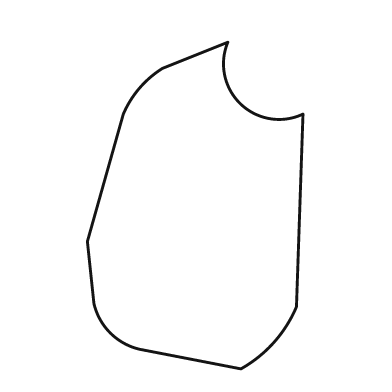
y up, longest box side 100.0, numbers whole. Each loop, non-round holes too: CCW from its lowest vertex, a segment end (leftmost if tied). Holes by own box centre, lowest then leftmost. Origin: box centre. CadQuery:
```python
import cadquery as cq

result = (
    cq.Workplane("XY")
    .moveTo(14.0, -50.0)
    .threePointArc((24.0, -42.0), (31.0, -31.0))
    .lineTo(33.0, 28.0)
    .threePointArc((14.0, 31.0), (10.0, 50.0))
    .lineTo(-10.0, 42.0)
    .threePointArc((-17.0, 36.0), (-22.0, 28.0))
    .lineTo(-33.0, -11.0)
    .lineTo(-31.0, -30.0)
    .threePointArc((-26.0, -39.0), (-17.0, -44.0))
    .close()
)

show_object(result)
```